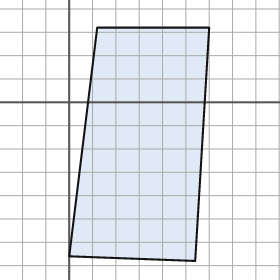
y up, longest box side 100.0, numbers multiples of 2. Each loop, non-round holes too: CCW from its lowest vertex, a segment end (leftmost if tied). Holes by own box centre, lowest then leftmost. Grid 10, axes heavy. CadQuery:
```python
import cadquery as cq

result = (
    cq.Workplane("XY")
    .moveTo(54.0, -68.0)
    .lineTo(60.0, 32.0)
    .lineTo(12.0, 32.0)
    .lineTo(0.0, -66.0)
    .close()
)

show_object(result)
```